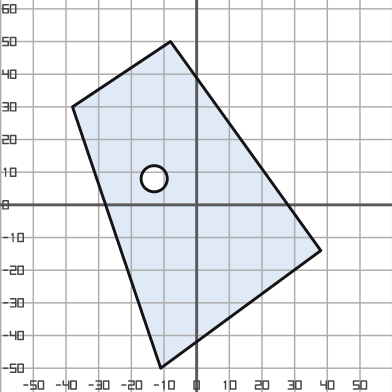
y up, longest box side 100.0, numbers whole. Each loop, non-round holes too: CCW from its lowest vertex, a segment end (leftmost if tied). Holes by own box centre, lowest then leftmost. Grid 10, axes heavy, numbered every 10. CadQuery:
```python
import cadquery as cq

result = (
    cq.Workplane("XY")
    .moveTo(-11.0, -50.0)
    .lineTo(38.0, -14.0)
    .lineTo(-8.0, 50.0)
    .lineTo(-38.0, 30.0)
    .close()
    .moveTo(-13.0, 8.0)
    .circle(4.0)
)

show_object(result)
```